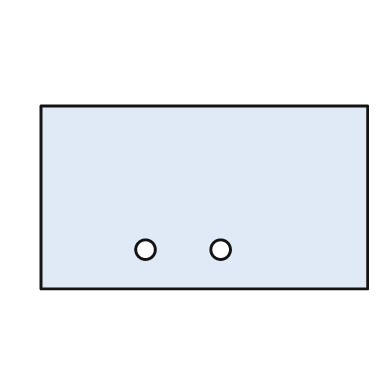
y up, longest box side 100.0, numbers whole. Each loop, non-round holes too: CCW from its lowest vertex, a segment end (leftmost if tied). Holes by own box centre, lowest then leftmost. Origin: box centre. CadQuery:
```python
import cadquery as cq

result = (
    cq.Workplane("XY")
    .moveTo(-50.0, -28.0)
    .lineTo(50.0, -28.0)
    .lineTo(50.0, 28.0)
    .lineTo(-50.0, 28.0)
    .close()
    .moveTo(-18.0, -16.0)
    .circle(3.0)
    .moveTo(5.0, -16.0)
    .circle(3.0)
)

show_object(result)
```